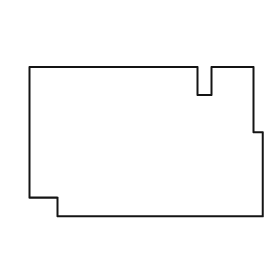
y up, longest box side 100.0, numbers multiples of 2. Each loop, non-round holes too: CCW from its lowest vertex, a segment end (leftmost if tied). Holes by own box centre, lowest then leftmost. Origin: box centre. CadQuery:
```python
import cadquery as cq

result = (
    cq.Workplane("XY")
    .moveTo(-38.0, -32.0)
    .lineTo(50.0, -32.0)
    .lineTo(50.0, 4.0)
    .lineTo(46.0, 4.0)
    .lineTo(46.0, 32.0)
    .lineTo(28.0, 32.0)
    .lineTo(28.0, 20.0)
    .lineTo(22.0, 20.0)
    .lineTo(22.0, 32.0)
    .lineTo(-50.0, 32.0)
    .lineTo(-50.0, -24.0)
    .lineTo(-38.0, -24.0)
    .close()
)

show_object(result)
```